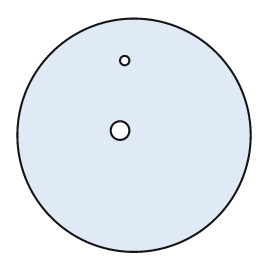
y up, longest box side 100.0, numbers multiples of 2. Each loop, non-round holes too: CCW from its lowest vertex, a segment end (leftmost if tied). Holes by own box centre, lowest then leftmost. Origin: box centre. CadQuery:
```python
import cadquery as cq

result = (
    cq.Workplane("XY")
    .moveTo(0.0, 0.0)
    .circle(50.0)
    .moveTo(-6.0, 2.0)
    .circle(4.0)
    .moveTo(-4.0, 32.0)
    .circle(2.0)
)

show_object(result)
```